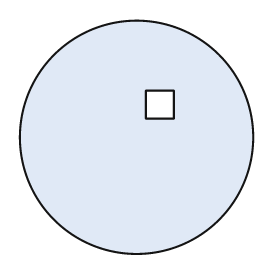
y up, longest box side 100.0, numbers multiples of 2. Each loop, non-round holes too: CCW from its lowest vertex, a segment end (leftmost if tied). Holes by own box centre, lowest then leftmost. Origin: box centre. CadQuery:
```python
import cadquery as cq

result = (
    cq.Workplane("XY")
    .moveTo(0.0, 0.0)
    .circle(50.0)
    .moveTo(4.0, 8.0)
    .lineTo(16.0, 8.0)
    .lineTo(16.0, 20.0)
    .lineTo(4.0, 20.0)
    .close()
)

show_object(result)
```